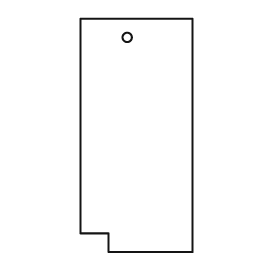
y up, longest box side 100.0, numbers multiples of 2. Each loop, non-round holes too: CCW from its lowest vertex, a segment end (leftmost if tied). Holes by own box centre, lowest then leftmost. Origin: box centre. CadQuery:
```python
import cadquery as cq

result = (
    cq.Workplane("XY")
    .moveTo(-12.0, -50.0)
    .lineTo(24.0, -50.0)
    .lineTo(24.0, 50.0)
    .lineTo(-24.0, 50.0)
    .lineTo(-24.0, -42.0)
    .lineTo(-12.0, -42.0)
    .close()
    .moveTo(-4.0, 42.0)
    .circle(2.0)
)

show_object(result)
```